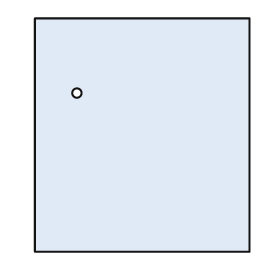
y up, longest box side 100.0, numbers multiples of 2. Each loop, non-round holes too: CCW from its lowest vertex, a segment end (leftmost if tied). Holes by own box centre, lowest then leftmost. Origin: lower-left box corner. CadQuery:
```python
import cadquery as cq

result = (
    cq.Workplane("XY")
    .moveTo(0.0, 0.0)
    .lineTo(92.0, 0.0)
    .lineTo(92.0, 100.0)
    .lineTo(0.0, 100.0)
    .close()
    .moveTo(18.0, 68.0)
    .circle(2.0)
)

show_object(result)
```